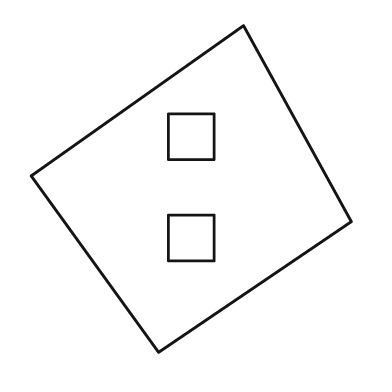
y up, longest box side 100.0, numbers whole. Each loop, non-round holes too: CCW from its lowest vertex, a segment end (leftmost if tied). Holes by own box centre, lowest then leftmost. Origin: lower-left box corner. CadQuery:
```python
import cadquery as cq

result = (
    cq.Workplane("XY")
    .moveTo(39.0, 0.0)
    .lineTo(98.0, 40.0)
    .lineTo(65.0, 100.0)
    .lineTo(0.0, 54.0)
    .close()
    .moveTo(42.0, 28.0)
    .lineTo(56.0, 28.0)
    .lineTo(56.0, 42.0)
    .lineTo(42.0, 42.0)
    .close()
    .moveTo(42.0, 59.0)
    .lineTo(56.0, 59.0)
    .lineTo(56.0, 73.0)
    .lineTo(42.0, 73.0)
    .close()
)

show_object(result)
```